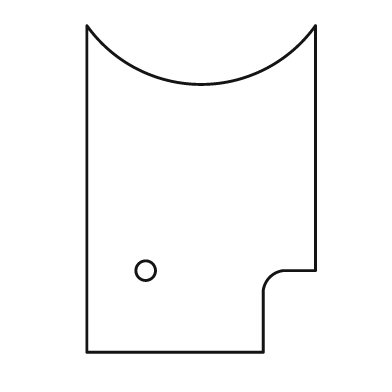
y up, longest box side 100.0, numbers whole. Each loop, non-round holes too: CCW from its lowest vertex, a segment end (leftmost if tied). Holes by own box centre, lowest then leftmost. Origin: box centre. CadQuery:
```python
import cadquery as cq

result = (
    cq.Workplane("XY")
    .moveTo(-35.0, -50.0)
    .lineTo(19.0, -50.0)
    .lineTo(19.0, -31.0)
    .threePointArc((21.0, -27.0), (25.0, -25.0))
    .lineTo(35.0, -25.0)
    .lineTo(35.0, 50.0)
    .threePointArc((0.0, 32.0), (-35.0, 50.0))
    .close()
    .moveTo(-17.0, -25.0)
    .circle(3.0)
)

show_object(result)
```